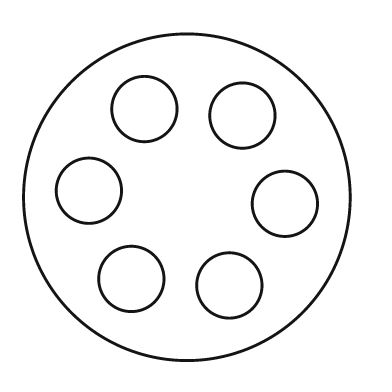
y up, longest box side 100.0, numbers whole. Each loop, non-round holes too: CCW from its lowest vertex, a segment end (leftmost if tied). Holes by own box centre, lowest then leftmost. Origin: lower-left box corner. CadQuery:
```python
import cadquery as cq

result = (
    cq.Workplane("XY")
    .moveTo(50.0, 50.0)
    .circle(50.0)
    .moveTo(63.0, 23.0)
    .circle(10.0)
    .moveTo(33.0, 25.0)
    .circle(10.0)
    .moveTo(80.0, 48.0)
    .circle(10.0)
    .moveTo(20.0, 52.0)
    .circle(10.0)
    .moveTo(67.0, 75.0)
    .circle(10.0)
    .moveTo(37.0, 77.0)
    .circle(10.0)
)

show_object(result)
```